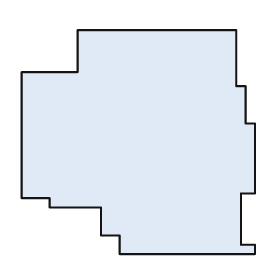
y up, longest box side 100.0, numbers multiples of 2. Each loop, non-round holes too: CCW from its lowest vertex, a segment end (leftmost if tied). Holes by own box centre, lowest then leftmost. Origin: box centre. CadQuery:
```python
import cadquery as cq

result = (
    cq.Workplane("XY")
    .moveTo(-8.0, -48.0)
    .lineTo(50.0, -48.0)
    .lineTo(50.0, -44.0)
    .lineTo(44.0, -44.0)
    .lineTo(44.0, -22.0)
    .lineTo(50.0, -22.0)
    .lineTo(50.0, 8.0)
    .lineTo(46.0, 8.0)
    .lineTo(46.0, 24.0)
    .lineTo(42.0, 24.0)
    .lineTo(42.0, 48.0)
    .lineTo(-26.0, 48.0)
    .lineTo(-26.0, 30.0)
    .lineTo(-50.0, 30.0)
    .lineTo(-50.0, -24.0)
    .lineTo(-38.0, -24.0)
    .lineTo(-38.0, -28.0)
    .lineTo(-16.0, -28.0)
    .lineTo(-16.0, -40.0)
    .lineTo(-8.0, -40.0)
    .close()
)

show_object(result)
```